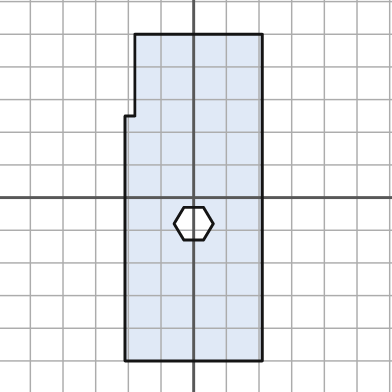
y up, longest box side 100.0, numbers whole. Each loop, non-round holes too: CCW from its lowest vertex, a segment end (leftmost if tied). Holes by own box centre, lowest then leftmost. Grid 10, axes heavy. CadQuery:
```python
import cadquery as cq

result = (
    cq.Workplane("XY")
    .moveTo(-21.0, -50.0)
    .lineTo(21.0, -50.0)
    .lineTo(21.0, 50.0)
    .lineTo(-18.0, 50.0)
    .lineTo(-18.0, 25.0)
    .lineTo(-21.0, 25.0)
    .close()
    .moveTo(-3.0, -13.0)
    .lineTo(3.0, -13.0)
    .lineTo(6.0, -8.0)
    .lineTo(3.0, -3.0)
    .lineTo(-3.0, -3.0)
    .lineTo(-6.0, -8.0)
    .close()
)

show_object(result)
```